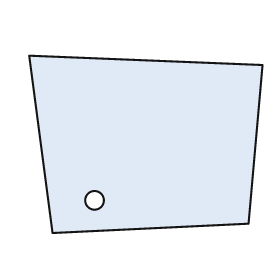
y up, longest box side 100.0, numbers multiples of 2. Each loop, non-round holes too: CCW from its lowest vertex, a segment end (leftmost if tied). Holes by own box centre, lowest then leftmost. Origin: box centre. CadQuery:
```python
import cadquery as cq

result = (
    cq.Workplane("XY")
    .moveTo(-40.0, -38.0)
    .lineTo(44.0, -34.0)
    .lineTo(50.0, 34.0)
    .lineTo(-50.0, 38.0)
    .close()
    .moveTo(-22.0, -24.0)
    .circle(4.0)
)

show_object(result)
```